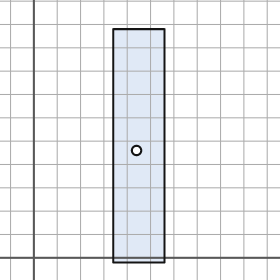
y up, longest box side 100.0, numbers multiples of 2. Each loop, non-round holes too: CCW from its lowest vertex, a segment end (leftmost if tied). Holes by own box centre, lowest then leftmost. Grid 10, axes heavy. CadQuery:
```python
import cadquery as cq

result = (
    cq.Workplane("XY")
    .moveTo(34.0, -2.0)
    .lineTo(56.0, -2.0)
    .lineTo(56.0, 98.0)
    .lineTo(34.0, 98.0)
    .close()
    .moveTo(44.0, 46.0)
    .circle(2.0)
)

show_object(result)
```